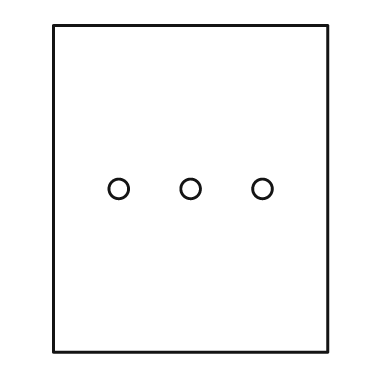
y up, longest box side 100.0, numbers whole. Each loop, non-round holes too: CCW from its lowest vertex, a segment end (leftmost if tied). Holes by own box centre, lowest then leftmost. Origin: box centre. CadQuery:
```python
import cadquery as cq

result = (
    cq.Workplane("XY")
    .moveTo(-42.0, -50.0)
    .lineTo(42.0, -50.0)
    .lineTo(42.0, 50.0)
    .lineTo(-42.0, 50.0)
    .close()
    .moveTo(-22.0, 0.0)
    .circle(3.0)
    .moveTo(0.0, 0.0)
    .circle(3.0)
    .moveTo(22.0, 0.0)
    .circle(3.0)
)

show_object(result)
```